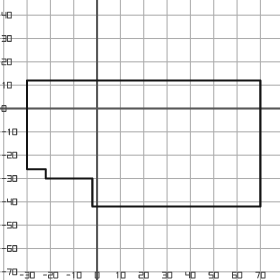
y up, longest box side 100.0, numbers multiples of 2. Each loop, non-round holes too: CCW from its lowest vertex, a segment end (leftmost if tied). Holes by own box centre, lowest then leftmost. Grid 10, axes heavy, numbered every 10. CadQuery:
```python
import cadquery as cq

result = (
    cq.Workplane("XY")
    .moveTo(-2.0, -42.0)
    .lineTo(70.0, -42.0)
    .lineTo(70.0, 12.0)
    .lineTo(-30.0, 12.0)
    .lineTo(-30.0, -26.0)
    .lineTo(-22.0, -26.0)
    .lineTo(-22.0, -30.0)
    .lineTo(-2.0, -30.0)
    .close()
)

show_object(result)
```